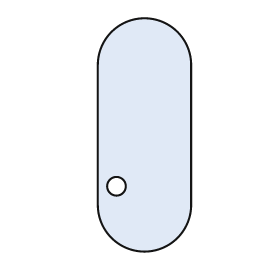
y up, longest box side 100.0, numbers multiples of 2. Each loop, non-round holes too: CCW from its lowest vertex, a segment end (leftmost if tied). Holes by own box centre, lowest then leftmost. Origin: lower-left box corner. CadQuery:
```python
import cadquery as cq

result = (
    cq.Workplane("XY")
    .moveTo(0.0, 20.0)
    .threePointArc((20.0, 0.0), (40.0, 20.0))
    .lineTo(40.0, 80.0)
    .threePointArc((20.0, 100.0), (0.0, 80.0))
    .close()
    .moveTo(8.0, 28.0)
    .circle(4.0)
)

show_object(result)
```